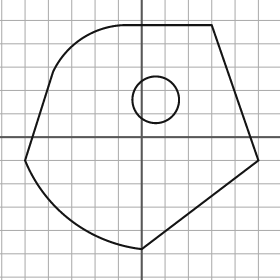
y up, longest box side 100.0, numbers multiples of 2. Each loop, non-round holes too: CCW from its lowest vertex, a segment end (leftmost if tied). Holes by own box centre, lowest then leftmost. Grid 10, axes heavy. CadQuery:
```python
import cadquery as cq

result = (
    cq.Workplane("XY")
    .moveTo(0.0, -48.0)
    .lineTo(50.0, -10.0)
    .lineTo(30.0, 48.0)
    .lineTo(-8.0, 48.0)
    .threePointArc((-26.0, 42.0), (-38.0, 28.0))
    .lineTo(-50.0, -10.0)
    .threePointArc((-30.0, -36.0), (0.0, -48.0))
    .close()
    .moveTo(6.0, 16.0)
    .circle(10.0)
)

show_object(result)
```